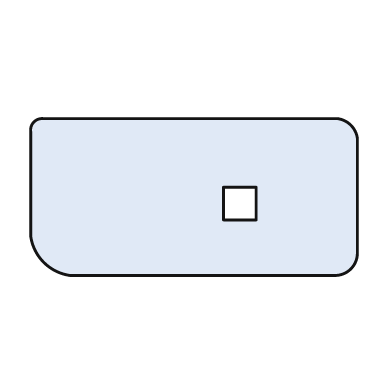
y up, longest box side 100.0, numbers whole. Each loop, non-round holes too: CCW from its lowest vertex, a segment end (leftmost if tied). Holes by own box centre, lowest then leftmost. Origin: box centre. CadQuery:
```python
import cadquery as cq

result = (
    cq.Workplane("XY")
    .moveTo(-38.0, -24.0)
    .lineTo(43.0, -24.0)
    .threePointArc((48.0, -22.0), (50.0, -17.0))
    .lineTo(50.0, 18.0)
    .threePointArc((48.0, 22.0), (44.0, 24.0))
    .lineTo(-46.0, 24.0)
    .threePointArc((-49.0, 23.0), (-50.0, 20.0))
    .lineTo(-50.0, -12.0)
    .threePointArc((-46.0, -20.0), (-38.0, -24.0))
    .close()
    .moveTo(9.0, -7.0)
    .lineTo(19.0, -7.0)
    .lineTo(19.0, 3.0)
    .lineTo(9.0, 3.0)
    .close()
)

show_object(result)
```